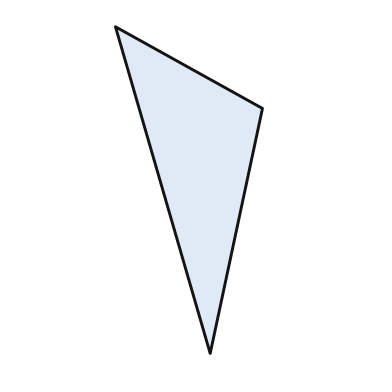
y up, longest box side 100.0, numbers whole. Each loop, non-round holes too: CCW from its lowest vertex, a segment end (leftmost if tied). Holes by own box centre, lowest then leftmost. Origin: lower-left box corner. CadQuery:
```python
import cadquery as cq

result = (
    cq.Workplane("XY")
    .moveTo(29.0, 0.0)
    .lineTo(45.0, 75.0)
    .lineTo(0.0, 100.0)
    .close()
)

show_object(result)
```